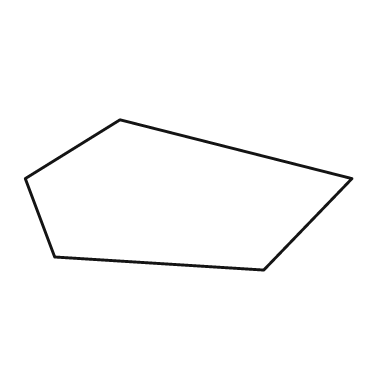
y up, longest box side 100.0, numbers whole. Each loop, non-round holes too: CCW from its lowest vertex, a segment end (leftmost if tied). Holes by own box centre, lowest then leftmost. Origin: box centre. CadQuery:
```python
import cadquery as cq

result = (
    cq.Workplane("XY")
    .moveTo(23.0, -23.0)
    .lineTo(50.0, 5.0)
    .lineTo(-21.0, 23.0)
    .lineTo(-50.0, 5.0)
    .lineTo(-41.0, -19.0)
    .close()
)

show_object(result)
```